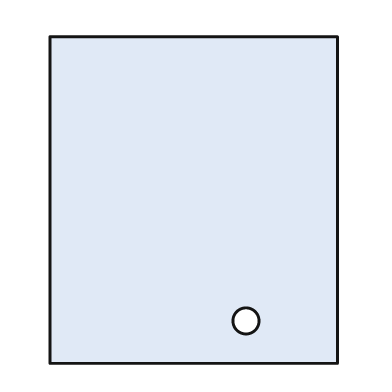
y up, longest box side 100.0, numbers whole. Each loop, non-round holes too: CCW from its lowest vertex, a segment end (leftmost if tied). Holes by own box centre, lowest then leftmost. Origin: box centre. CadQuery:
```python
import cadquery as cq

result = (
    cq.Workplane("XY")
    .moveTo(-44.0, -50.0)
    .lineTo(44.0, -50.0)
    .lineTo(44.0, 50.0)
    .lineTo(-44.0, 50.0)
    .close()
    .moveTo(16.0, -37.0)
    .circle(4.0)
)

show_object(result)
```